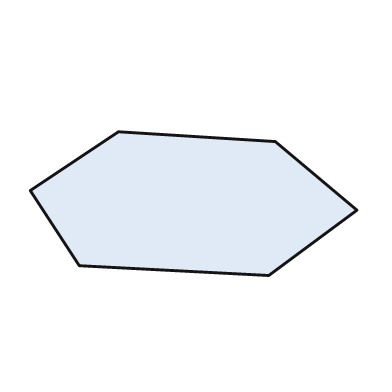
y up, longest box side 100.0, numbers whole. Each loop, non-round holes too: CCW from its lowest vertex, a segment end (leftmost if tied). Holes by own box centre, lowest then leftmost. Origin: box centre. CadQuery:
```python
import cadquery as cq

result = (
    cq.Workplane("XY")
    .moveTo(23.0, -22.0)
    .lineTo(50.0, -2.0)
    .lineTo(25.0, 19.0)
    .lineTo(-23.0, 22.0)
    .lineTo(-50.0, 4.0)
    .lineTo(-35.0, -19.0)
    .close()
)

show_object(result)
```